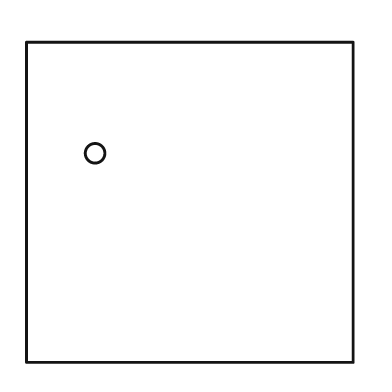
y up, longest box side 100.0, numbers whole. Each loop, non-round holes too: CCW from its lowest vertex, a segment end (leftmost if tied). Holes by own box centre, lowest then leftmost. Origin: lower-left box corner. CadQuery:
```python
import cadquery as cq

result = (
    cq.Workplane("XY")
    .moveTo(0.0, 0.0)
    .lineTo(100.0, 0.0)
    .lineTo(100.0, 98.0)
    .lineTo(0.0, 98.0)
    .close()
    .moveTo(21.0, 64.0)
    .circle(3.0)
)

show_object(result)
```